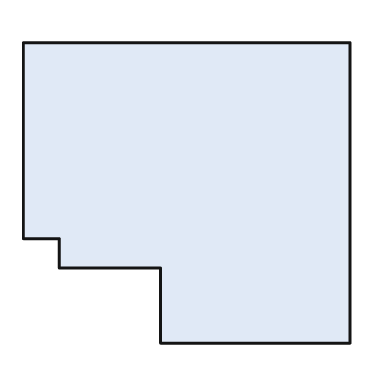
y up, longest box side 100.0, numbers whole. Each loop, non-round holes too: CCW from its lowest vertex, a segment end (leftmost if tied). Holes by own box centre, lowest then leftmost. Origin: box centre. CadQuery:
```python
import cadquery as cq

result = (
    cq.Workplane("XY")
    .moveTo(-8.0, -46.0)
    .lineTo(50.0, -46.0)
    .lineTo(50.0, 46.0)
    .lineTo(-50.0, 46.0)
    .lineTo(-50.0, -14.0)
    .lineTo(-39.0, -14.0)
    .lineTo(-39.0, -23.0)
    .lineTo(-8.0, -23.0)
    .close()
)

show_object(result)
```